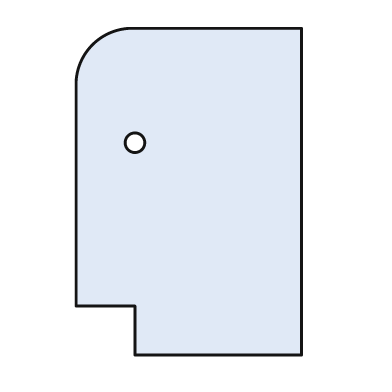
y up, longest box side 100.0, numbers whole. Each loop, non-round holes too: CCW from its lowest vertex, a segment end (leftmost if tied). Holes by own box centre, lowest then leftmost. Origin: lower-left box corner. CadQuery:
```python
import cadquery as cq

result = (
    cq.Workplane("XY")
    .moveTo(18.0, 0.0)
    .lineTo(69.0, 0.0)
    .lineTo(69.0, 100.0)
    .lineTo(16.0, 100.0)
    .threePointArc((5.0, 95.0), (0.0, 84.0))
    .lineTo(0.0, 15.0)
    .lineTo(18.0, 15.0)
    .close()
    .moveTo(18.0, 65.0)
    .circle(3.0)
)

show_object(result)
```